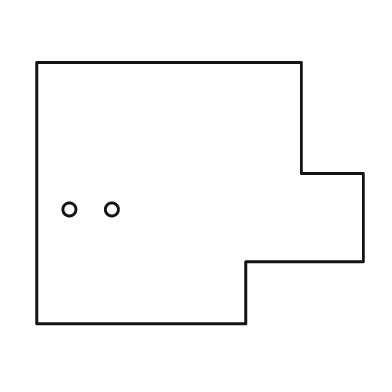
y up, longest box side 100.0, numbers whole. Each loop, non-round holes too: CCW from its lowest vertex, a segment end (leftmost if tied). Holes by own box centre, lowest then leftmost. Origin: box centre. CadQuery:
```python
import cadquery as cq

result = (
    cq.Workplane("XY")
    .moveTo(-50.0, -40.0)
    .lineTo(14.0, -40.0)
    .lineTo(14.0, -21.0)
    .lineTo(50.0, -21.0)
    .lineTo(50.0, 6.0)
    .lineTo(31.0, 6.0)
    .lineTo(31.0, 40.0)
    .lineTo(-50.0, 40.0)
    .close()
    .moveTo(-40.0, -5.0)
    .circle(2.0)
    .moveTo(-27.0, -5.0)
    .circle(2.0)
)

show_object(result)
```